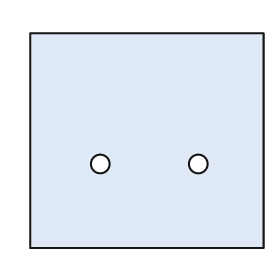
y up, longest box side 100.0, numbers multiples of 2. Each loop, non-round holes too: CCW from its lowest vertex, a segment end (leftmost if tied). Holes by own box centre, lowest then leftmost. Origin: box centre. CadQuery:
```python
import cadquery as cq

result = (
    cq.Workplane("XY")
    .moveTo(-50.0, -46.0)
    .lineTo(50.0, -46.0)
    .lineTo(50.0, 46.0)
    .lineTo(-50.0, 46.0)
    .close()
    .moveTo(-20.0, -10.0)
    .circle(4.0)
    .moveTo(22.0, -10.0)
    .circle(4.0)
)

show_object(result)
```